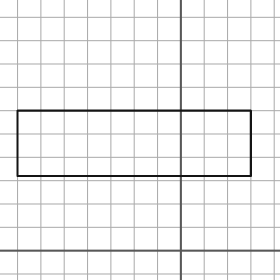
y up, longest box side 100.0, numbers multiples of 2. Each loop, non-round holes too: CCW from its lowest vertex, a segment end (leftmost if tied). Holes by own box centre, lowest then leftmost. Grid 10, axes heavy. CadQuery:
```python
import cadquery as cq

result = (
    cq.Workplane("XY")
    .moveTo(-70.0, 32.0)
    .lineTo(30.0, 32.0)
    .lineTo(30.0, 60.0)
    .lineTo(-70.0, 60.0)
    .close()
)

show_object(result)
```